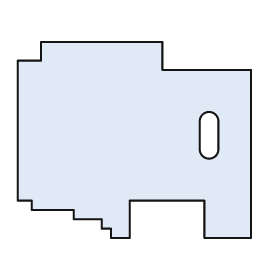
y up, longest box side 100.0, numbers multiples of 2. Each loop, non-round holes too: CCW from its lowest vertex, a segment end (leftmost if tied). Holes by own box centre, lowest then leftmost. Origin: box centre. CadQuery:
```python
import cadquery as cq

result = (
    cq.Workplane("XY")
    .moveTo(-10.0, -42.0)
    .lineTo(-2.0, -42.0)
    .lineTo(-2.0, -26.0)
    .lineTo(30.0, -26.0)
    .lineTo(30.0, -42.0)
    .lineTo(50.0, -42.0)
    .lineTo(50.0, 30.0)
    .lineTo(12.0, 30.0)
    .lineTo(12.0, 42.0)
    .lineTo(-40.0, 42.0)
    .lineTo(-40.0, 34.0)
    .lineTo(-50.0, 34.0)
    .lineTo(-50.0, -26.0)
    .lineTo(-44.0, -26.0)
    .lineTo(-44.0, -30.0)
    .lineTo(-26.0, -30.0)
    .lineTo(-26.0, -34.0)
    .lineTo(-14.0, -34.0)
    .lineTo(-14.0, -38.0)
    .lineTo(-10.0, -38.0)
    .close()
    .moveTo(28.0, -4.0)
    .threePointArc((32.0, -8.0), (36.0, -4.0))
    .lineTo(36.0, 8.0)
    .threePointArc((32.0, 12.0), (28.0, 8.0))
    .close()
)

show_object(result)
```